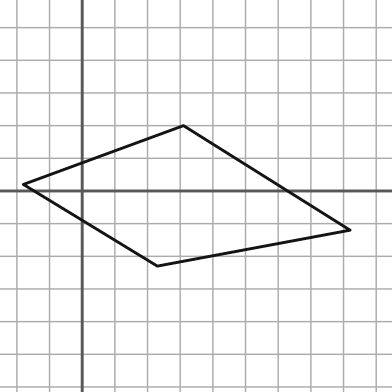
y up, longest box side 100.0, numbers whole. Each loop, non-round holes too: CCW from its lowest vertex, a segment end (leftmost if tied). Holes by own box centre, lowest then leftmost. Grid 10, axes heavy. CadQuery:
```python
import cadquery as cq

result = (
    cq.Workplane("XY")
    .moveTo(23.0, -23.0)
    .lineTo(82.0, -12.0)
    .lineTo(31.0, 20.0)
    .lineTo(-18.0, 2.0)
    .close()
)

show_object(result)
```